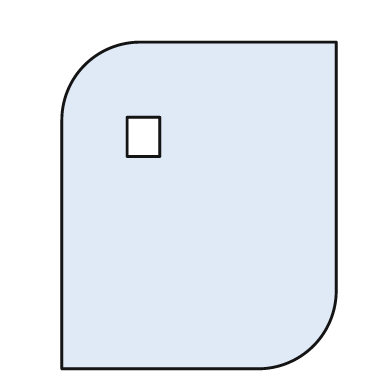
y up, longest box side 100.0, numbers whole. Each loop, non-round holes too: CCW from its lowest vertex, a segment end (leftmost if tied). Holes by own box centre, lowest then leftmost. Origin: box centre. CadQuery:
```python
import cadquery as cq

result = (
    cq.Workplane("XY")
    .moveTo(-42.0, -50.0)
    .lineTo(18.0, -50.0)
    .threePointArc((35.0, -43.0), (42.0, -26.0))
    .lineTo(42.0, 50.0)
    .lineTo(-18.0, 50.0)
    .threePointArc((-35.0, 43.0), (-42.0, 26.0))
    .close()
    .moveTo(-22.0, 15.0)
    .lineTo(-12.0, 15.0)
    .lineTo(-12.0, 27.0)
    .lineTo(-22.0, 27.0)
    .close()
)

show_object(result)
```